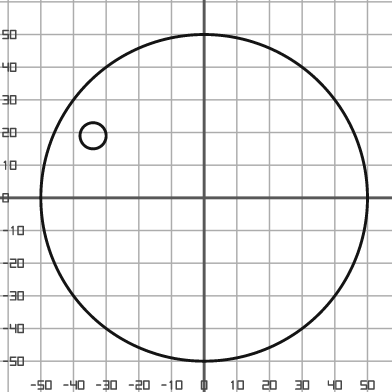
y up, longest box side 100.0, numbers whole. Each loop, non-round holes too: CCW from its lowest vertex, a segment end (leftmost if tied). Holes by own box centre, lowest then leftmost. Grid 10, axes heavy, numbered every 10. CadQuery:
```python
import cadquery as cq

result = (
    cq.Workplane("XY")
    .moveTo(0.0, 0.0)
    .circle(50.0)
    .moveTo(-34.0, 19.0)
    .circle(4.0)
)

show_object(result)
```